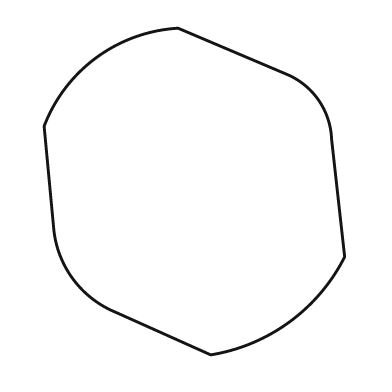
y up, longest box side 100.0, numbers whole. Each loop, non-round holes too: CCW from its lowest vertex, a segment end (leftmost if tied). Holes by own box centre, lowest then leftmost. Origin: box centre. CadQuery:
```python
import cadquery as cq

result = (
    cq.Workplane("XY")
    .moveTo(5.0, -50.0)
    .threePointArc((29.0, -40.0), (46.0, -20.0))
    .lineTo(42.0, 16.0)
    .threePointArc((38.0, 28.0), (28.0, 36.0))
    .lineTo(-5.0, 50.0)
    .threePointArc((-30.0, 41.0), (-46.0, 20.0))
    .lineTo(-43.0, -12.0)
    .threePointArc((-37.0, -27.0), (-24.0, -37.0))
    .close()
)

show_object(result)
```